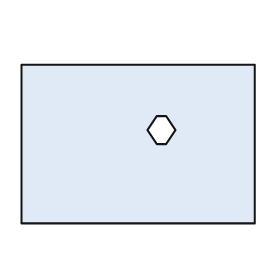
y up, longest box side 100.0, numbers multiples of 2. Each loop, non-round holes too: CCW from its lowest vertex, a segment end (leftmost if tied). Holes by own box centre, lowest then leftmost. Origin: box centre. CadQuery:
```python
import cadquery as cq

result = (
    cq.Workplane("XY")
    .moveTo(-50.0, -34.0)
    .lineTo(50.0, -34.0)
    .lineTo(50.0, 34.0)
    .lineTo(-50.0, 34.0)
    .close()
    .moveTo(8.0, 0.0)
    .lineTo(12.0, 0.0)
    .lineTo(16.0, 6.0)
    .lineTo(12.0, 12.0)
    .lineTo(8.0, 12.0)
    .lineTo(4.0, 6.0)
    .close()
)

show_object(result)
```